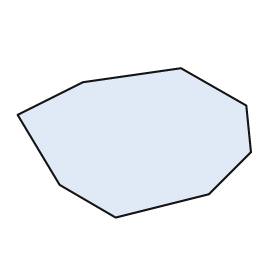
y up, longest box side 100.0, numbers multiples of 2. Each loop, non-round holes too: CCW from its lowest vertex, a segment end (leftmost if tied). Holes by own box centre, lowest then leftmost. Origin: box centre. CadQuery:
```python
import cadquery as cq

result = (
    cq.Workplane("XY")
    .moveTo(-8.0, -32.0)
    .lineTo(32.0, -22.0)
    .lineTo(50.0, -4.0)
    .lineTo(48.0, 16.0)
    .lineTo(20.0, 32.0)
    .lineTo(-22.0, 26.0)
    .lineTo(-50.0, 12.0)
    .lineTo(-32.0, -18.0)
    .close()
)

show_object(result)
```